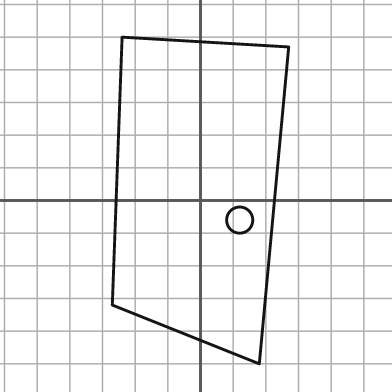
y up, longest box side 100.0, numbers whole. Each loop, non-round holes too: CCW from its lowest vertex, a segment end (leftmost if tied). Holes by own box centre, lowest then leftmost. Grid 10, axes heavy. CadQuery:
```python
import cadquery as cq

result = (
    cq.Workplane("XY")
    .moveTo(18.0, -50.0)
    .lineTo(27.0, 47.0)
    .lineTo(-24.0, 50.0)
    .lineTo(-27.0, -32.0)
    .close()
    .moveTo(12.0, -6.0)
    .circle(4.0)
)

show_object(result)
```